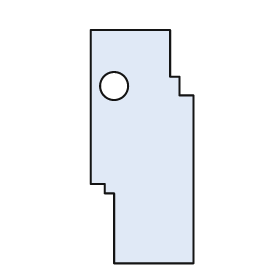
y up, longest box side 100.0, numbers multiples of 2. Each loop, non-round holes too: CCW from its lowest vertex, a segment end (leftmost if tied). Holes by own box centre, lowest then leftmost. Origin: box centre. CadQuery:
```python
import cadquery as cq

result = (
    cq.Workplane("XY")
    .moveTo(-12.0, -50.0)
    .lineTo(22.0, -50.0)
    .lineTo(22.0, 22.0)
    .lineTo(16.0, 22.0)
    .lineTo(16.0, 30.0)
    .lineTo(12.0, 30.0)
    .lineTo(12.0, 50.0)
    .lineTo(-22.0, 50.0)
    .lineTo(-22.0, -16.0)
    .lineTo(-16.0, -16.0)
    .lineTo(-16.0, -20.0)
    .lineTo(-12.0, -20.0)
    .close()
    .moveTo(-12.0, 26.0)
    .circle(6.0)
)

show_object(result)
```